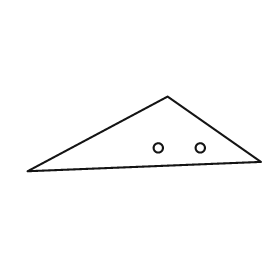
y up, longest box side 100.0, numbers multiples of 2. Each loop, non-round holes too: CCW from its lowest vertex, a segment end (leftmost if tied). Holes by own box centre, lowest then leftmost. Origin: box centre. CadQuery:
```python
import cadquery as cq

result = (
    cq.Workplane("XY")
    .moveTo(-50.0, -16.0)
    .lineTo(50.0, -12.0)
    .lineTo(10.0, 16.0)
    .close()
    .moveTo(6.0, -6.0)
    .circle(2.0)
    .moveTo(24.0, -6.0)
    .circle(2.0)
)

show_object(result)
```